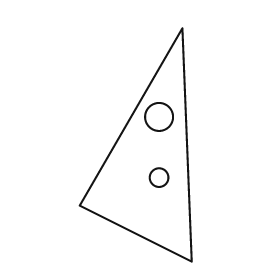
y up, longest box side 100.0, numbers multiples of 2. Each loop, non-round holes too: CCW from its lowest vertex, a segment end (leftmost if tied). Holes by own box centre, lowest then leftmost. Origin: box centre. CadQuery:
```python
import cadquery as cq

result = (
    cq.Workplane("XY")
    .moveTo(24.0, -50.0)
    .lineTo(20.0, 50.0)
    .lineTo(-24.0, -26.0)
    .close()
    .moveTo(10.0, -14.0)
    .circle(4.0)
    .moveTo(10.0, 12.0)
    .circle(6.0)
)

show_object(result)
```